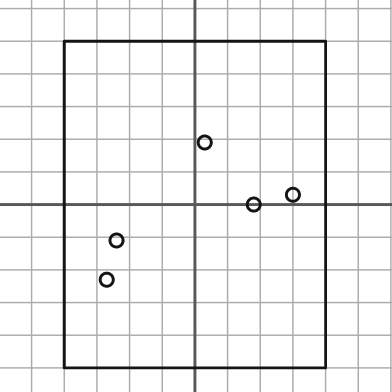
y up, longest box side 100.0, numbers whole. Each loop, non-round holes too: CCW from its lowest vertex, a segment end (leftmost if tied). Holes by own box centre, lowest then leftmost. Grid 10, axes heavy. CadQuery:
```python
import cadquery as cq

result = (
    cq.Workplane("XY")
    .moveTo(-40.0, -50.0)
    .lineTo(40.0, -50.0)
    .lineTo(40.0, 50.0)
    .lineTo(-40.0, 50.0)
    .close()
    .moveTo(-27.0, -23.0)
    .circle(2.0)
    .moveTo(-24.0, -11.0)
    .circle(2.0)
    .moveTo(18.0, 0.0)
    .circle(2.0)
    .moveTo(30.0, 3.0)
    .circle(2.0)
    .moveTo(3.0, 19.0)
    .circle(2.0)
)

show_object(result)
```